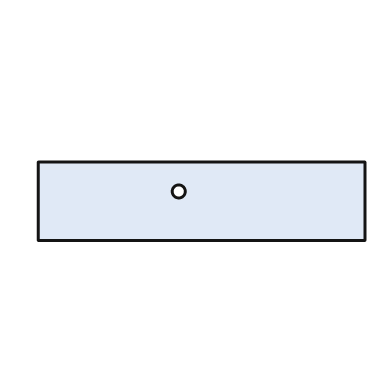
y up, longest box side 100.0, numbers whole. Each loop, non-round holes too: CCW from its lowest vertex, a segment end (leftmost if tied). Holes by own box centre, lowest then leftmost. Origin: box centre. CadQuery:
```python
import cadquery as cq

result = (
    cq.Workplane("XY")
    .moveTo(-50.0, -12.0)
    .lineTo(50.0, -12.0)
    .lineTo(50.0, 12.0)
    .lineTo(-50.0, 12.0)
    .close()
    .moveTo(-7.0, 3.0)
    .circle(2.0)
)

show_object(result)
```